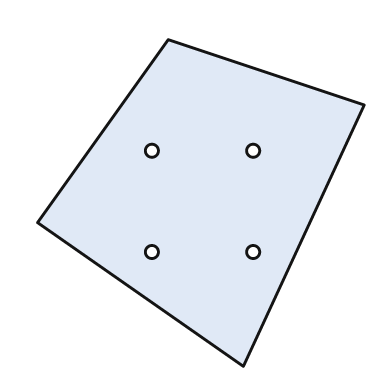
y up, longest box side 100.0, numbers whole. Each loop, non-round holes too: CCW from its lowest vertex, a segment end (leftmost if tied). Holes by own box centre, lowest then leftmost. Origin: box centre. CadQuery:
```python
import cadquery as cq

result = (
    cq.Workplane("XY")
    .moveTo(13.0, -50.0)
    .lineTo(50.0, 30.0)
    .lineTo(-10.0, 50.0)
    .lineTo(-50.0, -6.0)
    .close()
    .moveTo(-15.0, -15.0)
    .circle(2.0)
    .moveTo(16.0, -15.0)
    .circle(2.0)
    .moveTo(-15.0, 16.0)
    .circle(2.0)
    .moveTo(16.0, 16.0)
    .circle(2.0)
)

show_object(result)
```